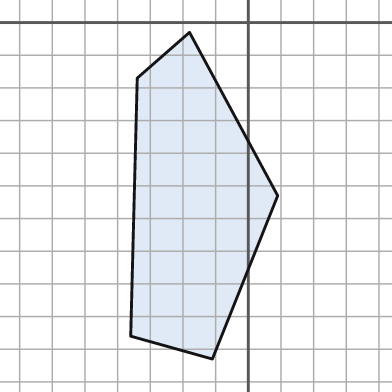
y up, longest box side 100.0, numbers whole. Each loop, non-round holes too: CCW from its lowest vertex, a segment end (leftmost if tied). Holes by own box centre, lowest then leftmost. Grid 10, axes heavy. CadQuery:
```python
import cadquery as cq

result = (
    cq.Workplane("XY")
    .moveTo(-11.0, -103.0)
    .lineTo(9.0, -53.0)
    .lineTo(-18.0, -3.0)
    .lineTo(-34.0, -17.0)
    .lineTo(-36.0, -96.0)
    .close()
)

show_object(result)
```